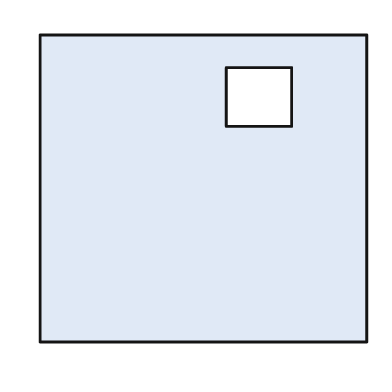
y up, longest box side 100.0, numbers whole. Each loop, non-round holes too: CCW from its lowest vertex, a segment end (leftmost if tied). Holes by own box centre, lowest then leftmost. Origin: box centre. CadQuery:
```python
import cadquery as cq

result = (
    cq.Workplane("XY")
    .moveTo(-50.0, -47.0)
    .lineTo(50.0, -47.0)
    .lineTo(50.0, 47.0)
    .lineTo(-50.0, 47.0)
    .close()
    .moveTo(7.0, 19.0)
    .lineTo(27.0, 19.0)
    .lineTo(27.0, 37.0)
    .lineTo(7.0, 37.0)
    .close()
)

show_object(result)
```